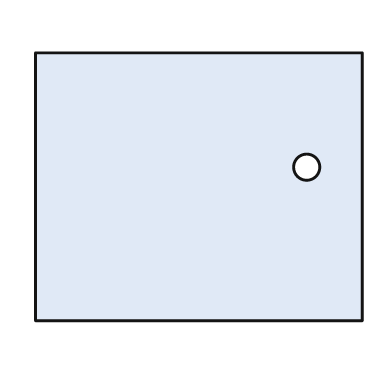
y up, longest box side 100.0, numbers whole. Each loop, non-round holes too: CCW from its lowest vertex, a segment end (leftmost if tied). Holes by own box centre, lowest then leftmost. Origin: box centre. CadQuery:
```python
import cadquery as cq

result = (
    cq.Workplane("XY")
    .moveTo(-50.0, -41.0)
    .lineTo(50.0, -41.0)
    .lineTo(50.0, 41.0)
    .lineTo(-50.0, 41.0)
    .close()
    .moveTo(33.0, 6.0)
    .circle(4.0)
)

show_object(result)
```